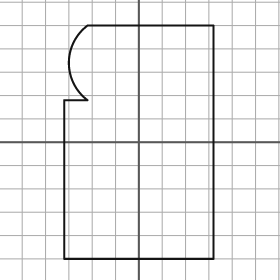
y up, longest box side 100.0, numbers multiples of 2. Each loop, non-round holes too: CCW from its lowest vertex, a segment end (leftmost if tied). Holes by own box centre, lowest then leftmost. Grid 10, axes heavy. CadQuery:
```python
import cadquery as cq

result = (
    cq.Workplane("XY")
    .moveTo(-32.0, -50.0)
    .lineTo(32.0, -50.0)
    .lineTo(32.0, 50.0)
    .lineTo(-22.0, 50.0)
    .threePointArc((-30.0, 34.0), (-22.0, 18.0))
    .lineTo(-32.0, 18.0)
    .close()
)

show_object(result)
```